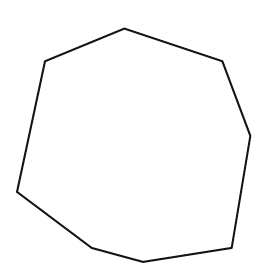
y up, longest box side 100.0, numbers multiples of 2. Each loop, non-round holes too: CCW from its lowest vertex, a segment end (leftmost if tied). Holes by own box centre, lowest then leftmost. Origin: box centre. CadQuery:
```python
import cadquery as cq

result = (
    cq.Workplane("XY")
    .moveTo(4.0, -50.0)
    .lineTo(42.0, -44.0)
    .lineTo(50.0, 4.0)
    .lineTo(38.0, 36.0)
    .lineTo(-4.0, 50.0)
    .lineTo(-38.0, 36.0)
    .lineTo(-50.0, -20.0)
    .lineTo(-18.0, -44.0)
    .close()
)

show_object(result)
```